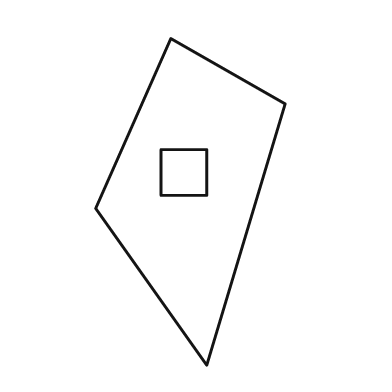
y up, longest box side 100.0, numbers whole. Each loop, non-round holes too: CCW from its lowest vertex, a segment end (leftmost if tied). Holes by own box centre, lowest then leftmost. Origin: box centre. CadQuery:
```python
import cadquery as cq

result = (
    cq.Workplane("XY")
    .moveTo(5.0, -50.0)
    .lineTo(29.0, 30.0)
    .lineTo(-6.0, 50.0)
    .lineTo(-29.0, -2.0)
    .close()
    .moveTo(-9.0, 2.0)
    .lineTo(5.0, 2.0)
    .lineTo(5.0, 16.0)
    .lineTo(-9.0, 16.0)
    .close()
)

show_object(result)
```